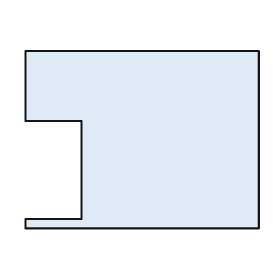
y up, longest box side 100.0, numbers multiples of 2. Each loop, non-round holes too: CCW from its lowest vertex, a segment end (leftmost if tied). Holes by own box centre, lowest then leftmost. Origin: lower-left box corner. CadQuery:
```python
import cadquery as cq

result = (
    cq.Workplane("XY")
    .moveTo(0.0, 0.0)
    .lineTo(100.0, 0.0)
    .lineTo(100.0, 76.0)
    .lineTo(0.0, 76.0)
    .lineTo(0.0, 46.0)
    .lineTo(24.0, 46.0)
    .lineTo(24.0, 4.0)
    .lineTo(0.0, 4.0)
    .close()
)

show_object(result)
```